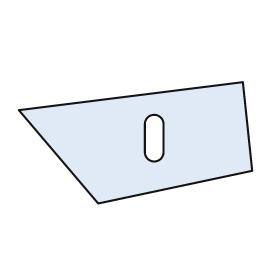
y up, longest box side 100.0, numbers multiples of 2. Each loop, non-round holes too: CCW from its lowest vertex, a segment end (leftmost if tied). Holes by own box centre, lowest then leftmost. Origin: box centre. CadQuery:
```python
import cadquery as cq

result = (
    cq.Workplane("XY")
    .moveTo(-16.0, -26.0)
    .lineTo(50.0, -12.0)
    .lineTo(46.0, 26.0)
    .lineTo(-50.0, 14.0)
    .close()
    .moveTo(4.0, -4.0)
    .threePointArc((8.0, -8.0), (12.0, -4.0))
    .lineTo(12.0, 8.0)
    .threePointArc((8.0, 12.0), (4.0, 8.0))
    .close()
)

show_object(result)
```